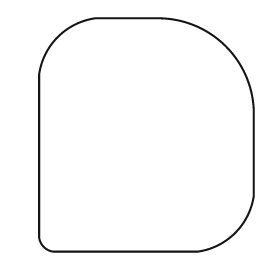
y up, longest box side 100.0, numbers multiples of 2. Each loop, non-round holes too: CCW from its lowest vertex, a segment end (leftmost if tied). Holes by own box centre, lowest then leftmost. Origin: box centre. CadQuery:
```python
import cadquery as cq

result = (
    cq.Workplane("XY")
    .moveTo(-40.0, -50.0)
    .lineTo(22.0, -50.0)
    .threePointArc((38.0, -42.0), (46.0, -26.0))
    .lineTo(46.0, 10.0)
    .threePointArc((34.0, 38.0), (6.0, 50.0))
    .lineTo(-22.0, 50.0)
    .threePointArc((-38.0, 42.0), (-46.0, 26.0))
    .lineTo(-46.0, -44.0)
    .threePointArc((-44.0, -48.0), (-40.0, -50.0))
    .close()
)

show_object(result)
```